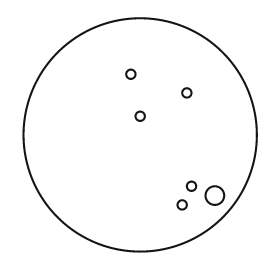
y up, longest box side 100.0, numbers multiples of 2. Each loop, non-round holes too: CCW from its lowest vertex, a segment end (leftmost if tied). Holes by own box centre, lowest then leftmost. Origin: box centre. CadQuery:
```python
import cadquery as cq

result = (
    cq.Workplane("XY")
    .moveTo(0.0, 0.0)
    .circle(50.0)
    .moveTo(18.0, -30.0)
    .circle(2.0)
    .moveTo(32.0, -26.0)
    .circle(4.0)
    .moveTo(22.0, -22.0)
    .circle(2.0)
    .moveTo(0.0, 8.0)
    .circle(2.0)
    .moveTo(20.0, 18.0)
    .circle(2.0)
    .moveTo(-4.0, 26.0)
    .circle(2.0)
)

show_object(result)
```